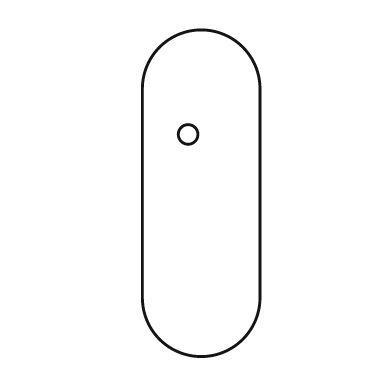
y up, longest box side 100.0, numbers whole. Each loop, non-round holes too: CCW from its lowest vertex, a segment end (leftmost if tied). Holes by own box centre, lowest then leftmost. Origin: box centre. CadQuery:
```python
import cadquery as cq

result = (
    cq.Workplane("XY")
    .moveTo(-18.0, -32.0)
    .threePointArc((0.0, -50.0), (18.0, -32.0))
    .lineTo(18.0, 32.0)
    .threePointArc((0.0, 50.0), (-18.0, 32.0))
    .close()
    .moveTo(-4.0, 18.0)
    .circle(3.0)
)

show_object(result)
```